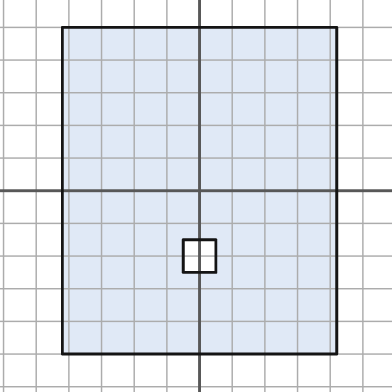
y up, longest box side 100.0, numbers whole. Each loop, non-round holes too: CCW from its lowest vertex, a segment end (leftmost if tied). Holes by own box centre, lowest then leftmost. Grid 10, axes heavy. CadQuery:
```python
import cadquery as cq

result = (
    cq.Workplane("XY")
    .moveTo(-42.0, -50.0)
    .lineTo(42.0, -50.0)
    .lineTo(42.0, 50.0)
    .lineTo(-42.0, 50.0)
    .close()
    .moveTo(-5.0, -25.0)
    .lineTo(5.0, -25.0)
    .lineTo(5.0, -15.0)
    .lineTo(-5.0, -15.0)
    .close()
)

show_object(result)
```